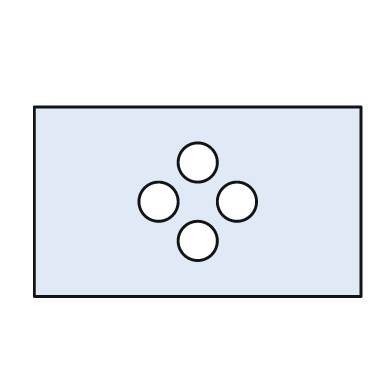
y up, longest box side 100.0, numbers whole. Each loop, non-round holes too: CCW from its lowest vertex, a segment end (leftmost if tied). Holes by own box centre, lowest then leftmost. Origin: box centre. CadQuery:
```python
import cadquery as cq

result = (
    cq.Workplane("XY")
    .moveTo(-50.0, -29.0)
    .lineTo(50.0, -29.0)
    .lineTo(50.0, 29.0)
    .lineTo(-50.0, 29.0)
    .close()
    .moveTo(0.0, -12.0)
    .circle(6.0)
    .moveTo(-12.0, 0.0)
    .circle(6.0)
    .moveTo(12.0, 0.0)
    .circle(6.0)
    .moveTo(0.0, 12.0)
    .circle(6.0)
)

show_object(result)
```